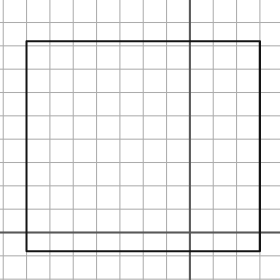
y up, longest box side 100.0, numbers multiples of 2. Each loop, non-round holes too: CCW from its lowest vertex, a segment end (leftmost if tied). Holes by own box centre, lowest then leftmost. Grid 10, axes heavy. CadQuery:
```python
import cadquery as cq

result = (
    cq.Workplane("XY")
    .moveTo(-70.0, -8.0)
    .lineTo(30.0, -8.0)
    .lineTo(30.0, 82.0)
    .lineTo(-70.0, 82.0)
    .close()
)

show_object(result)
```